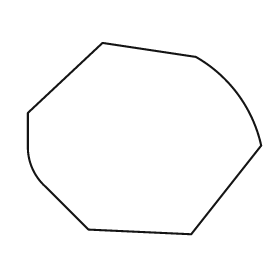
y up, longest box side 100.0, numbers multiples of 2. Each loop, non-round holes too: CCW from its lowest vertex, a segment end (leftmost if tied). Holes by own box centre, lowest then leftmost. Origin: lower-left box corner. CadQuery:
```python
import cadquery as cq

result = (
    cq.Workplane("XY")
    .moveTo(70.0, 0.0)
    .lineTo(100.0, 38.0)
    .threePointArc((90.0, 60.0), (72.0, 76.0))
    .lineTo(32.0, 82.0)
    .lineTo(0.0, 52.0)
    .lineTo(0.0, 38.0)
    .threePointArc((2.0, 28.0), (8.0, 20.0))
    .lineTo(26.0, 2.0)
    .close()
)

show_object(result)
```